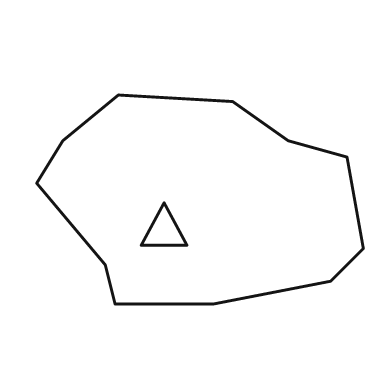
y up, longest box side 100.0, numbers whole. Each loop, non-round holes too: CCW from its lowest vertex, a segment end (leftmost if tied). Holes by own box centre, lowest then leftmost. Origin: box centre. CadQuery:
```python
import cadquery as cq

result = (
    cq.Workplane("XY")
    .moveTo(-26.0, -32.0)
    .lineTo(4.0, -32.0)
    .lineTo(40.0, -25.0)
    .lineTo(50.0, -15.0)
    .lineTo(45.0, 13.0)
    .lineTo(27.0, 18.0)
    .lineTo(10.0, 30.0)
    .lineTo(-25.0, 32.0)
    .lineTo(-42.0, 18.0)
    .lineTo(-50.0, 5.0)
    .lineTo(-29.0, -20.0)
    .close()
    .moveTo(-18.0, -14.0)
    .lineTo(-4.0, -14.0)
    .lineTo(-11.0, -1.0)
    .close()
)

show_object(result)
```